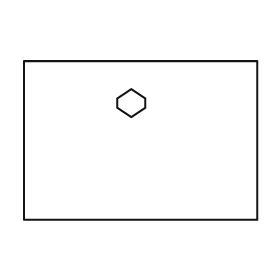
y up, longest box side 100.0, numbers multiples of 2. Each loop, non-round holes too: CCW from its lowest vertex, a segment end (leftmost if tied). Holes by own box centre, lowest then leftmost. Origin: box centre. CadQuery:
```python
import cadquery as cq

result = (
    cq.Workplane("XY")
    .moveTo(-50.0, -34.0)
    .lineTo(50.0, -34.0)
    .lineTo(50.0, 34.0)
    .lineTo(-50.0, 34.0)
    .close()
    .moveTo(-4.0, 10.0)
    .lineTo(2.0, 14.0)
    .lineTo(2.0, 18.0)
    .lineTo(-4.0, 22.0)
    .lineTo(-10.0, 18.0)
    .lineTo(-10.0, 14.0)
    .close()
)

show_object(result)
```